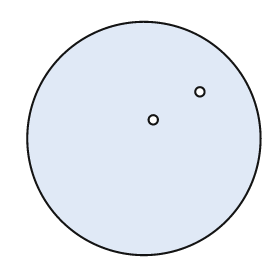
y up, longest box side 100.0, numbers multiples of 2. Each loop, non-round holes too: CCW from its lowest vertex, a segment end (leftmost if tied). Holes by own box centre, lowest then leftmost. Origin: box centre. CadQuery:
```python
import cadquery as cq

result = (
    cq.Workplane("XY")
    .moveTo(0.0, 0.0)
    .circle(50.0)
    .moveTo(4.0, 8.0)
    .circle(2.0)
    .moveTo(24.0, 20.0)
    .circle(2.0)
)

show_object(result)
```